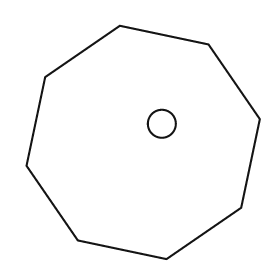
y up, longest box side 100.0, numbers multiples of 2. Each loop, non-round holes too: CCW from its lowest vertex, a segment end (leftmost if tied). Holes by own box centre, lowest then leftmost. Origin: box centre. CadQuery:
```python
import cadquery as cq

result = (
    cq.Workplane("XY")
    .moveTo(10.0, -50.0)
    .lineTo(42.0, -28.0)
    .lineTo(50.0, 10.0)
    .lineTo(28.0, 42.0)
    .lineTo(-10.0, 50.0)
    .lineTo(-42.0, 28.0)
    .lineTo(-50.0, -10.0)
    .lineTo(-28.0, -42.0)
    .close()
    .moveTo(8.0, 8.0)
    .circle(6.0)
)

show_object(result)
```